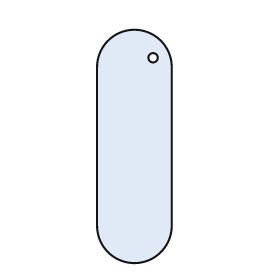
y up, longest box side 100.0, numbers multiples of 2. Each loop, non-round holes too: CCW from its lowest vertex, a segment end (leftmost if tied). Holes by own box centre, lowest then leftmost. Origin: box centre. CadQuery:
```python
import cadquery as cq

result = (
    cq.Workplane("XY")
    .moveTo(-16.0, -34.0)
    .threePointArc((0.0, -50.0), (16.0, -34.0))
    .lineTo(16.0, 34.0)
    .threePointArc((0.0, 50.0), (-16.0, 34.0))
    .close()
    .moveTo(8.0, 38.0)
    .circle(2.0)
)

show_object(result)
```